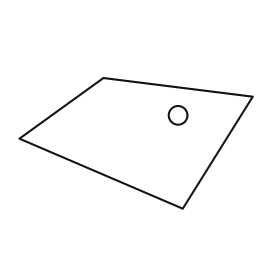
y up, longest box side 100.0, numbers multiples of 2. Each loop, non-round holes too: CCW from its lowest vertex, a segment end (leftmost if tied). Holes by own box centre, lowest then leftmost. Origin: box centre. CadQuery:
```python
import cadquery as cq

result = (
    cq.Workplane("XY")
    .moveTo(20.0, -28.0)
    .lineTo(50.0, 20.0)
    .lineTo(-14.0, 28.0)
    .lineTo(-50.0, 2.0)
    .close()
    .moveTo(18.0, 12.0)
    .circle(4.0)
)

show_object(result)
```